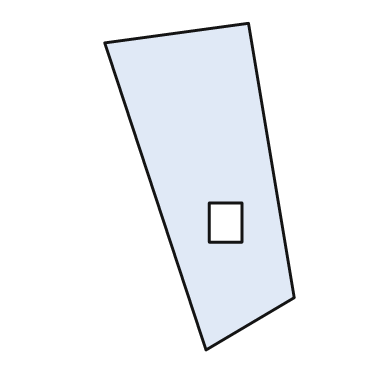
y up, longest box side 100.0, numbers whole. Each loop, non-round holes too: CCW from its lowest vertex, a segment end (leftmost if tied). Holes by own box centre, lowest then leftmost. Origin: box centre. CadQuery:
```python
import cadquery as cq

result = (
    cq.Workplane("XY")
    .moveTo(2.0, -50.0)
    .lineTo(29.0, -34.0)
    .lineTo(15.0, 50.0)
    .lineTo(-29.0, 44.0)
    .close()
    .moveTo(3.0, -17.0)
    .lineTo(13.0, -17.0)
    .lineTo(13.0, -5.0)
    .lineTo(3.0, -5.0)
    .close()
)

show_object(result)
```